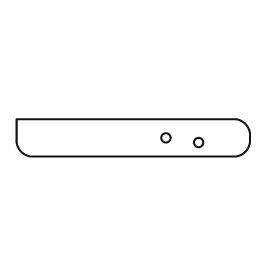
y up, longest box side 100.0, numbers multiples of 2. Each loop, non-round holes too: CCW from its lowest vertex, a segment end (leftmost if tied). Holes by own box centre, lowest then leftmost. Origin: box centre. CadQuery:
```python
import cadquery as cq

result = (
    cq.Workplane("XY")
    .moveTo(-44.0, -8.0)
    .lineTo(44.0, -8.0)
    .threePointArc((48.0, -6.0), (50.0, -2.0))
    .lineTo(50.0, 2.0)
    .threePointArc((48.0, 6.0), (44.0, 8.0))
    .lineTo(-50.0, 8.0)
    .lineTo(-50.0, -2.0)
    .threePointArc((-48.0, -6.0), (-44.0, -8.0))
    .close()
    .moveTo(28.0, -2.0)
    .circle(2.0)
    .moveTo(14.0, 0.0)
    .circle(2.0)
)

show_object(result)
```